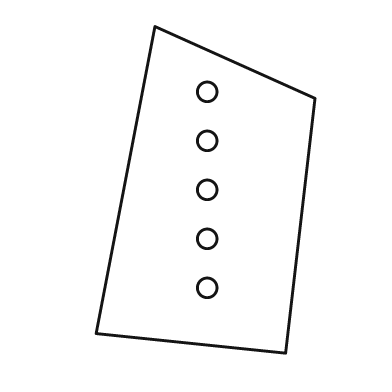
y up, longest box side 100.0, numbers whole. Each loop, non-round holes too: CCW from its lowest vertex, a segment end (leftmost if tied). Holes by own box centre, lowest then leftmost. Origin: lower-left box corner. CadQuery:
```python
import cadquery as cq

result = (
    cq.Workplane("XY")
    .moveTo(58.0, 0.0)
    .lineTo(67.0, 78.0)
    .lineTo(18.0, 100.0)
    .lineTo(0.0, 6.0)
    .close()
    .moveTo(34.0, 20.0)
    .circle(3.0)
    .moveTo(34.0, 35.0)
    .circle(3.0)
    .moveTo(34.0, 50.0)
    .circle(3.0)
    .moveTo(34.0, 65.0)
    .circle(3.0)
    .moveTo(34.0, 80.0)
    .circle(3.0)
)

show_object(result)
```